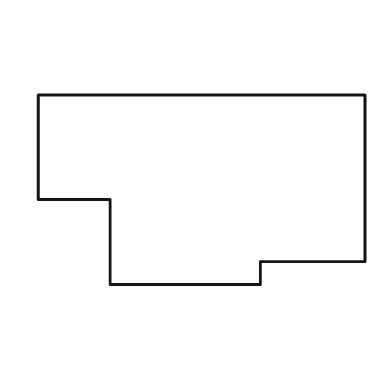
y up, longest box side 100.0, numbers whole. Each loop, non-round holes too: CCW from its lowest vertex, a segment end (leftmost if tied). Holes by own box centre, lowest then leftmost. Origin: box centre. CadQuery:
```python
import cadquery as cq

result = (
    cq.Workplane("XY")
    .moveTo(-28.0, -29.0)
    .lineTo(18.0, -29.0)
    .lineTo(18.0, -22.0)
    .lineTo(50.0, -22.0)
    .lineTo(50.0, 29.0)
    .lineTo(-50.0, 29.0)
    .lineTo(-50.0, -3.0)
    .lineTo(-28.0, -3.0)
    .close()
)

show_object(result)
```